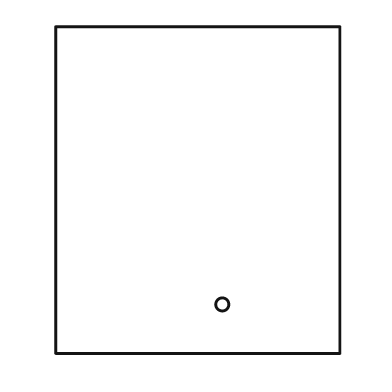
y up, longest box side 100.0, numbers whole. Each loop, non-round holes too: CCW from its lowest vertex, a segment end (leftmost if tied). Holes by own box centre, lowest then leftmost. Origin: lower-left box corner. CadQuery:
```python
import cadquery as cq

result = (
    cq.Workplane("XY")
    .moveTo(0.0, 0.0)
    .lineTo(87.0, 0.0)
    .lineTo(87.0, 100.0)
    .lineTo(0.0, 100.0)
    .close()
    .moveTo(51.0, 15.0)
    .circle(2.0)
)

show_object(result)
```